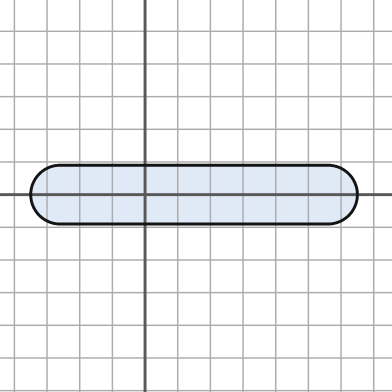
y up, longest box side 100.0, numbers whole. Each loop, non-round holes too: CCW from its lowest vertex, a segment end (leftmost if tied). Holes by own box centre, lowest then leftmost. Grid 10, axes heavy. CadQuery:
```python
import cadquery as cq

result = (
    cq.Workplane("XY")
    .moveTo(-26.0, -9.0)
    .lineTo(56.0, -9.0)
    .threePointArc((65.0, 0.0), (56.0, 9.0))
    .lineTo(-26.0, 9.0)
    .threePointArc((-35.0, 0.0), (-26.0, -9.0))
    .close()
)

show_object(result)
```